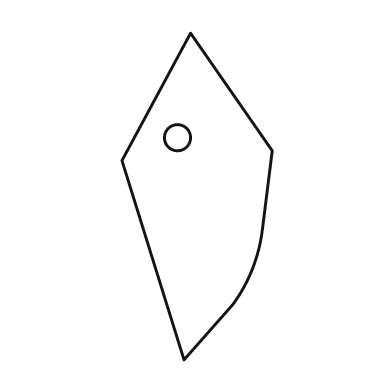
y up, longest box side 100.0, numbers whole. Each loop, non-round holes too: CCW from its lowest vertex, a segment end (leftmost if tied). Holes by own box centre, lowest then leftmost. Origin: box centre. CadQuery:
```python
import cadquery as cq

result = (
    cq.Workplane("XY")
    .moveTo(-4.0, -50.0)
    .lineTo(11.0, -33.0)
    .threePointArc((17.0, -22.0), (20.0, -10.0))
    .lineTo(23.0, 14.0)
    .lineTo(-2.0, 50.0)
    .lineTo(-23.0, 11.0)
    .close()
    .moveTo(-6.0, 18.0)
    .circle(4.0)
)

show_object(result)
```